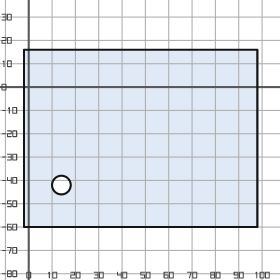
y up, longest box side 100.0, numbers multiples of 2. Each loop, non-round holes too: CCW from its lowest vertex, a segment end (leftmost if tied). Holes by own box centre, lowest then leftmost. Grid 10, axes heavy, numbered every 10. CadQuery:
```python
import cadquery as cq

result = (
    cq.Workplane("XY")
    .moveTo(-2.0, -60.0)
    .lineTo(98.0, -60.0)
    .lineTo(98.0, 16.0)
    .lineTo(-2.0, 16.0)
    .close()
    .moveTo(14.0, -42.0)
    .circle(4.0)
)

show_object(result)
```